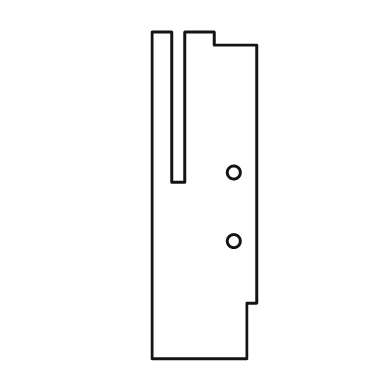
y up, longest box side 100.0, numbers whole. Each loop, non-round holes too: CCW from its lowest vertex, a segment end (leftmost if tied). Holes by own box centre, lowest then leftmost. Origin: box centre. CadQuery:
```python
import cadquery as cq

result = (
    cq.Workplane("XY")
    .moveTo(-16.0, -50.0)
    .lineTo(13.0, -50.0)
    .lineTo(13.0, -33.0)
    .lineTo(16.0, -33.0)
    .lineTo(16.0, 46.0)
    .lineTo(3.0, 46.0)
    .lineTo(3.0, 50.0)
    .lineTo(-6.0, 50.0)
    .lineTo(-6.0, 4.0)
    .lineTo(-10.0, 4.0)
    .lineTo(-10.0, 50.0)
    .lineTo(-16.0, 50.0)
    .close()
    .moveTo(9.0, -14.0)
    .circle(2.0)
    .moveTo(9.0, 7.0)
    .circle(2.0)
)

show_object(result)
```